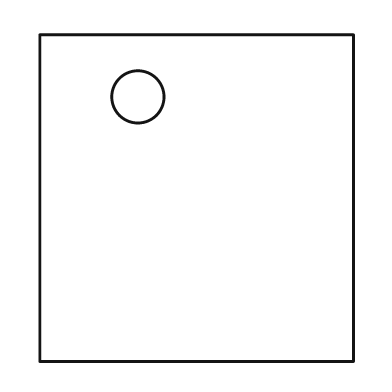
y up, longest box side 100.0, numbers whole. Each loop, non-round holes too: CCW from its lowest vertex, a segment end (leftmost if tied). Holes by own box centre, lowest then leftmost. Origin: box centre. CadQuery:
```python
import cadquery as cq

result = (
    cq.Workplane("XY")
    .moveTo(-48.0, -50.0)
    .lineTo(48.0, -50.0)
    .lineTo(48.0, 50.0)
    .lineTo(-48.0, 50.0)
    .close()
    .moveTo(-18.0, 31.0)
    .circle(8.0)
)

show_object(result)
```